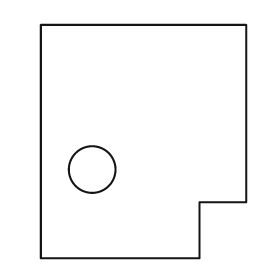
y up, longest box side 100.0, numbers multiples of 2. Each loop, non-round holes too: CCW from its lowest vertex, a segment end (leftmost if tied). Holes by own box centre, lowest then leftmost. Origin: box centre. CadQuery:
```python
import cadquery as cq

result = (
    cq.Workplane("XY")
    .moveTo(-44.0, -50.0)
    .lineTo(24.0, -50.0)
    .lineTo(24.0, -26.0)
    .lineTo(44.0, -26.0)
    .lineTo(44.0, 50.0)
    .lineTo(-44.0, 50.0)
    .close()
    .moveTo(-22.0, -12.0)
    .circle(10.0)
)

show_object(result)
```